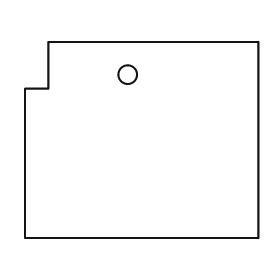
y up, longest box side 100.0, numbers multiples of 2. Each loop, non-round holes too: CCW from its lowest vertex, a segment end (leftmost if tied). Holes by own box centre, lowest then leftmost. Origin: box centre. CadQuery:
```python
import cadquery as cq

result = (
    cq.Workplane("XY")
    .moveTo(-50.0, -42.0)
    .lineTo(50.0, -42.0)
    .lineTo(50.0, 42.0)
    .lineTo(-40.0, 42.0)
    .lineTo(-40.0, 22.0)
    .lineTo(-50.0, 22.0)
    .close()
    .moveTo(-6.0, 28.0)
    .circle(4.0)
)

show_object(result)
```